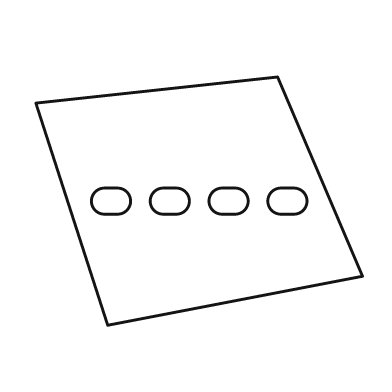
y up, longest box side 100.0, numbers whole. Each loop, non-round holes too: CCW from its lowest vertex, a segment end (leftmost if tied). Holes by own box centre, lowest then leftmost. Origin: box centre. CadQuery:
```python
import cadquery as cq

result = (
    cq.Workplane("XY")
    .moveTo(-28.0, -38.0)
    .lineTo(50.0, -23.0)
    .lineTo(24.0, 38.0)
    .lineTo(-50.0, 30.0)
    .close()
    .moveTo(-29.0, -4.0)
    .lineTo(-25.0, -4.0)
    .threePointArc((-21.0, 0.0), (-25.0, 4.0))
    .lineTo(-29.0, 4.0)
    .threePointArc((-33.0, 0.0), (-29.0, -4.0))
    .close()
    .moveTo(-11.0, -4.0)
    .lineTo(-7.0, -4.0)
    .threePointArc((-3.0, 0.0), (-7.0, 4.0))
    .lineTo(-11.0, 4.0)
    .threePointArc((-15.0, 0.0), (-11.0, -4.0))
    .close()
    .moveTo(7.0, -4.0)
    .lineTo(11.0, -4.0)
    .threePointArc((15.0, 0.0), (11.0, 4.0))
    .lineTo(7.0, 4.0)
    .threePointArc((3.0, 0.0), (7.0, -4.0))
    .close()
    .moveTo(25.0, -4.0)
    .lineTo(29.0, -4.0)
    .threePointArc((33.0, 0.0), (29.0, 4.0))
    .lineTo(25.0, 4.0)
    .threePointArc((21.0, 0.0), (25.0, -4.0))
    .close()
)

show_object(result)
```